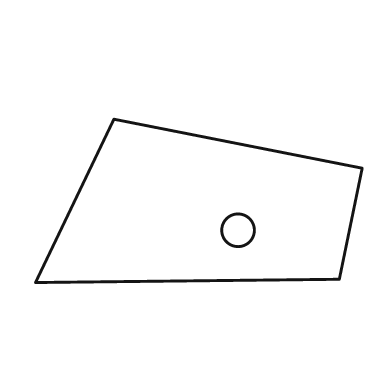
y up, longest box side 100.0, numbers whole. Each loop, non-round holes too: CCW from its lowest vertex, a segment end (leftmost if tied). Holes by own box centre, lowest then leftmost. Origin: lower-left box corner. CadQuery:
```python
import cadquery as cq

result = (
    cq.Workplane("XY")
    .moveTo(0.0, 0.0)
    .lineTo(93.0, 1.0)
    .lineTo(100.0, 35.0)
    .lineTo(24.0, 50.0)
    .close()
    .moveTo(62.0, 16.0)
    .circle(5.0)
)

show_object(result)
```